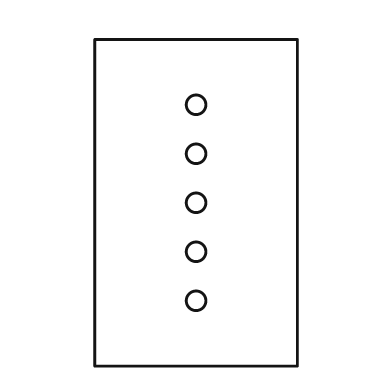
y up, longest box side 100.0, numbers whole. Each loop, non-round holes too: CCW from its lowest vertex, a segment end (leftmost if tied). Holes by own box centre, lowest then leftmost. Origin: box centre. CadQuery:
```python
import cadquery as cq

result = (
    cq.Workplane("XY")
    .moveTo(-31.0, -50.0)
    .lineTo(31.0, -50.0)
    .lineTo(31.0, 50.0)
    .lineTo(-31.0, 50.0)
    .close()
    .moveTo(0.0, -30.0)
    .circle(3.0)
    .moveTo(0.0, -15.0)
    .circle(3.0)
    .moveTo(0.0, 0.0)
    .circle(3.0)
    .moveTo(0.0, 15.0)
    .circle(3.0)
    .moveTo(0.0, 30.0)
    .circle(3.0)
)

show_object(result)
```